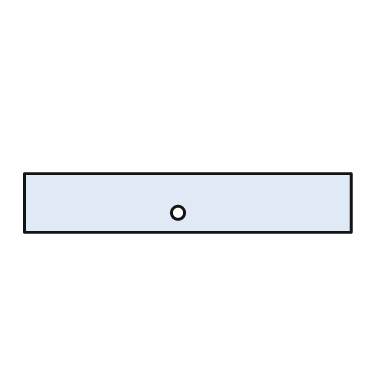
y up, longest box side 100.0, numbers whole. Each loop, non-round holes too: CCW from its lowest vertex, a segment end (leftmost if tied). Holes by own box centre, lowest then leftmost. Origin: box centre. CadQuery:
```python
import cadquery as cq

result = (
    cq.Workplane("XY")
    .moveTo(-50.0, -9.0)
    .lineTo(50.0, -9.0)
    .lineTo(50.0, 9.0)
    .lineTo(-50.0, 9.0)
    .close()
    .moveTo(-3.0, -3.0)
    .circle(2.0)
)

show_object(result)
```